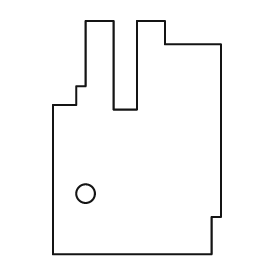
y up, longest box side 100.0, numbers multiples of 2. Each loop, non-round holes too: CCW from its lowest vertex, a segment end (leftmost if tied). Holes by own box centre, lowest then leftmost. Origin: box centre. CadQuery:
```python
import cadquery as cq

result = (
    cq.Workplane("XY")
    .moveTo(-36.0, -50.0)
    .lineTo(32.0, -50.0)
    .lineTo(32.0, -34.0)
    .lineTo(36.0, -34.0)
    .lineTo(36.0, 40.0)
    .lineTo(12.0, 40.0)
    .lineTo(12.0, 50.0)
    .lineTo(0.0, 50.0)
    .lineTo(0.0, 12.0)
    .lineTo(-10.0, 12.0)
    .lineTo(-10.0, 50.0)
    .lineTo(-22.0, 50.0)
    .lineTo(-22.0, 22.0)
    .lineTo(-26.0, 22.0)
    .lineTo(-26.0, 14.0)
    .lineTo(-36.0, 14.0)
    .close()
    .moveTo(-22.0, -24.0)
    .circle(4.0)
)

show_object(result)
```